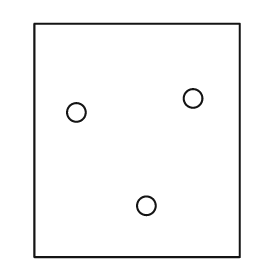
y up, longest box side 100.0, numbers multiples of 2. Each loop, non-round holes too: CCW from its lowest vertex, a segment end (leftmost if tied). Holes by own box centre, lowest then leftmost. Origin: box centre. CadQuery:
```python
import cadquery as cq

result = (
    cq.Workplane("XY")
    .moveTo(-44.0, -50.0)
    .lineTo(44.0, -50.0)
    .lineTo(44.0, 50.0)
    .lineTo(-44.0, 50.0)
    .close()
    .moveTo(4.0, -28.0)
    .circle(4.0)
    .moveTo(-26.0, 12.0)
    .circle(4.0)
    .moveTo(24.0, 18.0)
    .circle(4.0)
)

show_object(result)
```